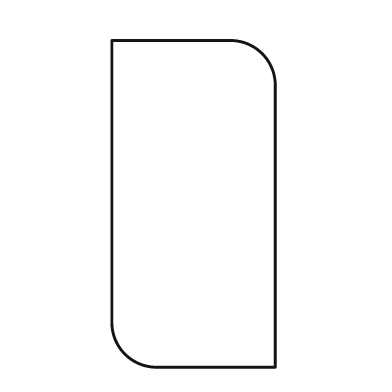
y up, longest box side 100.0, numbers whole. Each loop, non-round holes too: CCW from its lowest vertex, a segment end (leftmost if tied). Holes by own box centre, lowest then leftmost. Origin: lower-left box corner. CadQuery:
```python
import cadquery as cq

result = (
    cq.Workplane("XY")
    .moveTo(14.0, 0.0)
    .lineTo(50.0, 0.0)
    .lineTo(50.0, 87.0)
    .threePointArc((46.0, 96.0), (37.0, 100.0))
    .lineTo(0.0, 100.0)
    .lineTo(0.0, 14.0)
    .threePointArc((4.0, 4.0), (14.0, 0.0))
    .close()
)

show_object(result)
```